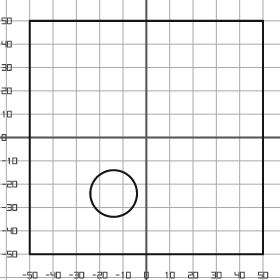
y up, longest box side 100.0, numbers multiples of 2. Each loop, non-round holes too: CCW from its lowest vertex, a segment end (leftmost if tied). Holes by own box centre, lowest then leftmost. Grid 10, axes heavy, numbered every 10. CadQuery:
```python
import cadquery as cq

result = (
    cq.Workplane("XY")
    .moveTo(-50.0, -50.0)
    .lineTo(50.0, -50.0)
    .lineTo(50.0, 50.0)
    .lineTo(-50.0, 50.0)
    .close()
    .moveTo(-14.0, -24.0)
    .circle(10.0)
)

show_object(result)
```